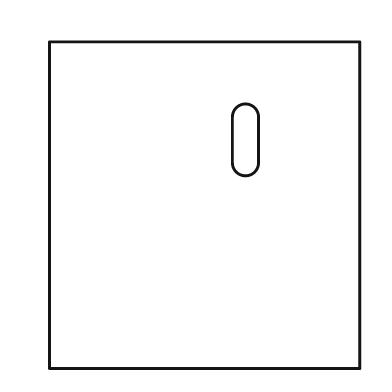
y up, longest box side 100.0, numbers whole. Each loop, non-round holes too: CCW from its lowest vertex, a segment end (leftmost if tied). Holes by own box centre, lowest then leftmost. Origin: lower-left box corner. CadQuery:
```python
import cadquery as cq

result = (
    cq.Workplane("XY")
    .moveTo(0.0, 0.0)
    .lineTo(95.0, 0.0)
    .lineTo(95.0, 100.0)
    .lineTo(0.0, 100.0)
    .close()
    .moveTo(56.0, 63.0)
    .threePointArc((60.0, 59.0), (64.0, 63.0))
    .lineTo(64.0, 77.0)
    .threePointArc((60.0, 81.0), (56.0, 77.0))
    .close()
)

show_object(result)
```